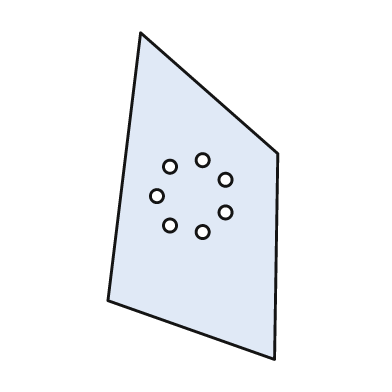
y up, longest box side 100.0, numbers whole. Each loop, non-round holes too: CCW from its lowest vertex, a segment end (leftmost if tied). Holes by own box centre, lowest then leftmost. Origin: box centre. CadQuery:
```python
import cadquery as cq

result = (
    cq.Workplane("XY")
    .moveTo(25.0, -50.0)
    .lineTo(26.0, 13.0)
    .lineTo(-16.0, 50.0)
    .lineTo(-26.0, -32.0)
    .close()
    .moveTo(3.0, -11.0)
    .circle(2.0)
    .moveTo(-7.0, -9.0)
    .circle(2.0)
    .moveTo(10.0, -5.0)
    .circle(2.0)
    .moveTo(-11.0, 0.0)
    .circle(2.0)
    .moveTo(10.0, 5.0)
    .circle(2.0)
    .moveTo(-7.0, 9.0)
    .circle(2.0)
    .moveTo(3.0, 11.0)
    .circle(2.0)
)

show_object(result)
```